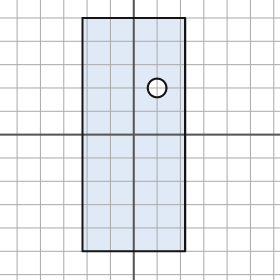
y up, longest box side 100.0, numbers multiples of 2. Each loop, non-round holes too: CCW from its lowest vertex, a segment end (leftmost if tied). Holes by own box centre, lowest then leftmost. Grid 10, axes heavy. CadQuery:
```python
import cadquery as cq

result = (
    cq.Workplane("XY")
    .moveTo(-22.0, -50.0)
    .lineTo(22.0, -50.0)
    .lineTo(22.0, 50.0)
    .lineTo(-22.0, 50.0)
    .close()
    .moveTo(10.0, 20.0)
    .circle(4.0)
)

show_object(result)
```